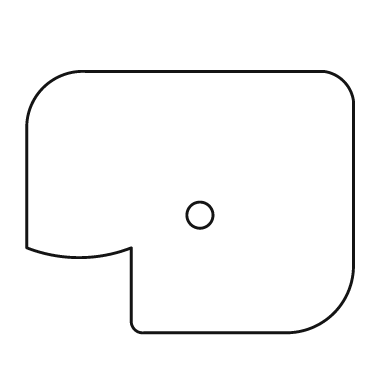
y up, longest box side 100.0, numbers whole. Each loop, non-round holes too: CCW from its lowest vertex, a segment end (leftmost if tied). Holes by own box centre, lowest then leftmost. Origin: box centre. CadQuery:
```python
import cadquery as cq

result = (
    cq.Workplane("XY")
    .moveTo(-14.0, -40.0)
    .lineTo(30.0, -40.0)
    .threePointArc((44.0, -34.0), (50.0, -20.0))
    .lineTo(50.0, 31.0)
    .threePointArc((47.0, 37.0), (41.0, 40.0))
    .lineTo(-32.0, 40.0)
    .threePointArc((-45.0, 35.0), (-50.0, 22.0))
    .lineTo(-50.0, -14.0)
    .threePointArc((-34.0, -17.0), (-18.0, -14.0))
    .lineTo(-18.0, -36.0)
    .threePointArc((-17.0, -39.0), (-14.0, -40.0))
    .close()
    .moveTo(3.0, -4.0)
    .circle(4.0)
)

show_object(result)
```